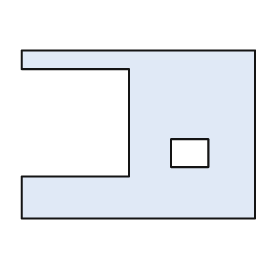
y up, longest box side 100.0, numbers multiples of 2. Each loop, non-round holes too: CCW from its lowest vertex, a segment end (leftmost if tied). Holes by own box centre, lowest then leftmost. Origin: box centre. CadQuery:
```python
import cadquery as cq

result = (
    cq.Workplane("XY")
    .moveTo(-50.0, -36.0)
    .lineTo(50.0, -36.0)
    .lineTo(50.0, 36.0)
    .lineTo(-50.0, 36.0)
    .lineTo(-50.0, 28.0)
    .lineTo(-4.0, 28.0)
    .lineTo(-4.0, -18.0)
    .lineTo(-50.0, -18.0)
    .close()
    .moveTo(14.0, -14.0)
    .lineTo(30.0, -14.0)
    .lineTo(30.0, -2.0)
    .lineTo(14.0, -2.0)
    .close()
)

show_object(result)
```